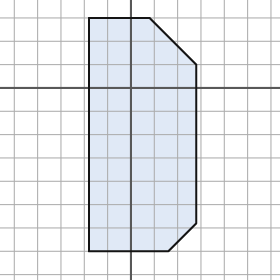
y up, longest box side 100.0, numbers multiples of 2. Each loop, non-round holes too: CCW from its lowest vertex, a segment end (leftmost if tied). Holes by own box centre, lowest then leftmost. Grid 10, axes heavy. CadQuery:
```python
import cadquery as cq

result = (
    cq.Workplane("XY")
    .moveTo(-18.0, -70.0)
    .lineTo(16.0, -70.0)
    .lineTo(28.0, -58.0)
    .lineTo(28.0, 10.0)
    .lineTo(8.0, 30.0)
    .lineTo(-18.0, 30.0)
    .close()
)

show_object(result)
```